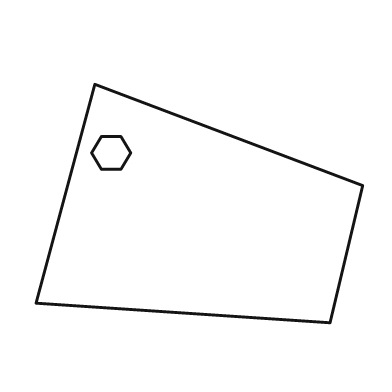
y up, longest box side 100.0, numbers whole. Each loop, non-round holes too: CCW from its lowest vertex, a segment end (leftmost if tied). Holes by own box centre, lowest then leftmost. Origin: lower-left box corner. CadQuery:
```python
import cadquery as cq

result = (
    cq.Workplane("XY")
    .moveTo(90.0, 0.0)
    .lineTo(100.0, 42.0)
    .lineTo(18.0, 73.0)
    .lineTo(0.0, 6.0)
    .close()
    .moveTo(20.0, 47.0)
    .lineTo(26.0, 47.0)
    .lineTo(29.0, 52.0)
    .lineTo(26.0, 57.0)
    .lineTo(20.0, 57.0)
    .lineTo(17.0, 52.0)
    .close()
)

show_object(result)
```